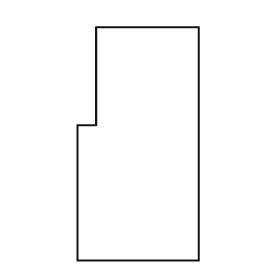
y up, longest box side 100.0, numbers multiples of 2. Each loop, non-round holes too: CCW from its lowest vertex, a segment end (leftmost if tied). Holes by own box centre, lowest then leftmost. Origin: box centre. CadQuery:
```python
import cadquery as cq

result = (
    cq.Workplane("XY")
    .moveTo(-26.0, -50.0)
    .lineTo(26.0, -50.0)
    .lineTo(26.0, 50.0)
    .lineTo(-18.0, 50.0)
    .lineTo(-18.0, 8.0)
    .lineTo(-26.0, 8.0)
    .close()
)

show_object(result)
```